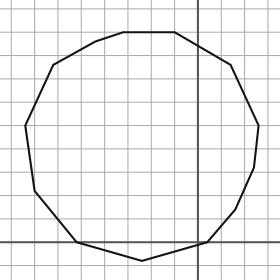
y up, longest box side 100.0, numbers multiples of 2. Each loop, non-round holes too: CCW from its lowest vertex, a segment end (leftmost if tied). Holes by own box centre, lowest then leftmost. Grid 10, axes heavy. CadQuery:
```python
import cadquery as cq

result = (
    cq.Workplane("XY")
    .moveTo(-24.0, -8.0)
    .lineTo(4.0, 0.0)
    .lineTo(16.0, 14.0)
    .lineTo(24.0, 32.0)
    .lineTo(26.0, 50.0)
    .lineTo(14.0, 76.0)
    .lineTo(-10.0, 90.0)
    .lineTo(-32.0, 90.0)
    .lineTo(-44.0, 86.0)
    .lineTo(-62.0, 76.0)
    .lineTo(-74.0, 50.0)
    .lineTo(-70.0, 22.0)
    .lineTo(-52.0, 0.0)
    .close()
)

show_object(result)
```